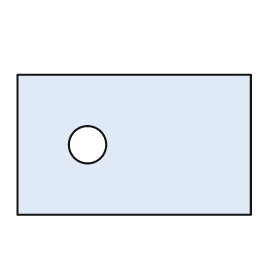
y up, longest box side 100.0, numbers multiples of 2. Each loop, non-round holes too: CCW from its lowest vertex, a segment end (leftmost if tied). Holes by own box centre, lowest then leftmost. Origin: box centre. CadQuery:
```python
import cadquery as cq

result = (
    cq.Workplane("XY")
    .moveTo(-50.0, -30.0)
    .lineTo(50.0, -30.0)
    .lineTo(50.0, 30.0)
    .lineTo(-50.0, 30.0)
    .close()
    .moveTo(-20.0, 0.0)
    .circle(8.0)
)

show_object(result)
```